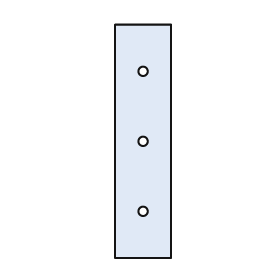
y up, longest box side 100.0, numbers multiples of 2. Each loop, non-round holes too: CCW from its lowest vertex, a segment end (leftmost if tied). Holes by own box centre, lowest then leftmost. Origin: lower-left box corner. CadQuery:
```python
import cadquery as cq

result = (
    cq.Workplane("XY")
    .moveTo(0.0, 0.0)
    .lineTo(24.0, 0.0)
    .lineTo(24.0, 100.0)
    .lineTo(0.0, 100.0)
    .close()
    .moveTo(12.0, 20.0)
    .circle(2.0)
    .moveTo(12.0, 50.0)
    .circle(2.0)
    .moveTo(12.0, 80.0)
    .circle(2.0)
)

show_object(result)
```